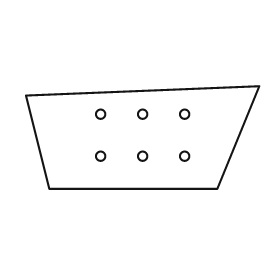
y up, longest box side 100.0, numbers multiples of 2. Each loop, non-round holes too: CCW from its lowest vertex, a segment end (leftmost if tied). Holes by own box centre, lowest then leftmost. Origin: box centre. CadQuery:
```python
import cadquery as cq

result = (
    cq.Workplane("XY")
    .moveTo(-40.0, -22.0)
    .lineTo(32.0, -22.0)
    .lineTo(50.0, 22.0)
    .lineTo(-50.0, 18.0)
    .close()
    .moveTo(-18.0, -8.0)
    .circle(2.0)
    .moveTo(0.0, -8.0)
    .circle(2.0)
    .moveTo(18.0, -8.0)
    .circle(2.0)
    .moveTo(-18.0, 10.0)
    .circle(2.0)
    .moveTo(0.0, 10.0)
    .circle(2.0)
    .moveTo(18.0, 10.0)
    .circle(2.0)
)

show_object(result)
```